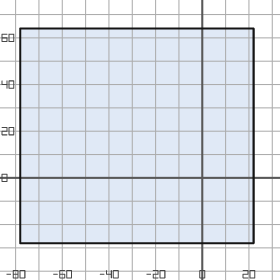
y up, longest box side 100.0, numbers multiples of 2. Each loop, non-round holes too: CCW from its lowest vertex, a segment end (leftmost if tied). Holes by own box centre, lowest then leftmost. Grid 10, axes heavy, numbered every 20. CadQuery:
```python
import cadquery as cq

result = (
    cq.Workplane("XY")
    .moveTo(-78.0, -28.0)
    .lineTo(22.0, -28.0)
    .lineTo(22.0, 64.0)
    .lineTo(-78.0, 64.0)
    .close()
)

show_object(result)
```